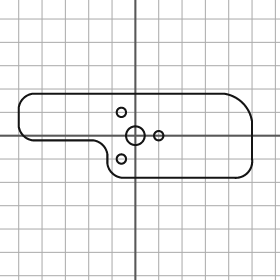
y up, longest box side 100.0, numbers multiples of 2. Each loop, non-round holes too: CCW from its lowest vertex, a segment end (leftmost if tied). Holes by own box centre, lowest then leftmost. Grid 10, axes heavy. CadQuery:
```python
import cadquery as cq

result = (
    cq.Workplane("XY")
    .moveTo(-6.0, -18.0)
    .lineTo(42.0, -18.0)
    .threePointArc((48.0, -16.0), (50.0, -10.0))
    .lineTo(50.0, 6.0)
    .threePointArc((46.0, 14.0), (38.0, 18.0))
    .lineTo(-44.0, 18.0)
    .threePointArc((-48.0, 16.0), (-50.0, 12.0))
    .lineTo(-50.0, 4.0)
    .threePointArc((-48.0, 0.0), (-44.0, -2.0))
    .lineTo(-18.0, -2.0)
    .threePointArc((-14.0, -4.0), (-12.0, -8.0))
    .lineTo(-12.0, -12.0)
    .threePointArc((-10.0, -16.0), (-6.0, -18.0))
    .close()
    .moveTo(-6.0, -10.0)
    .circle(2.0)
    .moveTo(0.0, 0.0)
    .circle(4.0)
    .moveTo(10.0, 0.0)
    .circle(2.0)
    .moveTo(-6.0, 10.0)
    .circle(2.0)
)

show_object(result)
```